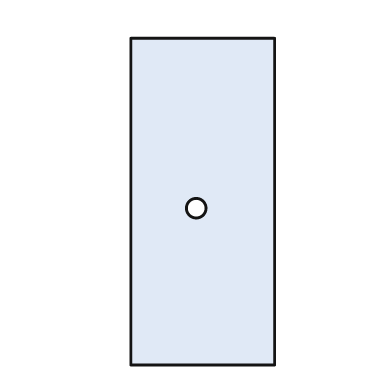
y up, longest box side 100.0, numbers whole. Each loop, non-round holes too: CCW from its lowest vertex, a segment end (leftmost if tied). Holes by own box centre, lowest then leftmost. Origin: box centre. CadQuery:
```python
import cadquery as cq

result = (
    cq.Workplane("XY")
    .moveTo(-22.0, -50.0)
    .lineTo(22.0, -50.0)
    .lineTo(22.0, 50.0)
    .lineTo(-22.0, 50.0)
    .close()
    .moveTo(-2.0, -2.0)
    .circle(3.0)
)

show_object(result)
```